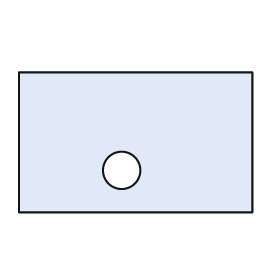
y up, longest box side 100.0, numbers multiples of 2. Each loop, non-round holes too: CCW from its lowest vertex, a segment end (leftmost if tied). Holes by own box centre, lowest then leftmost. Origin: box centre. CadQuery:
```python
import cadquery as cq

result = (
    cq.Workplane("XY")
    .moveTo(-50.0, -30.0)
    .lineTo(50.0, -30.0)
    .lineTo(50.0, 30.0)
    .lineTo(-50.0, 30.0)
    .close()
    .moveTo(-6.0, -12.0)
    .circle(8.0)
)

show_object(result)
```